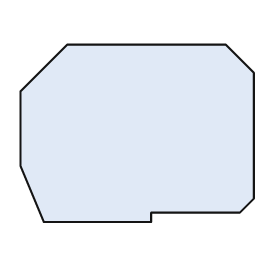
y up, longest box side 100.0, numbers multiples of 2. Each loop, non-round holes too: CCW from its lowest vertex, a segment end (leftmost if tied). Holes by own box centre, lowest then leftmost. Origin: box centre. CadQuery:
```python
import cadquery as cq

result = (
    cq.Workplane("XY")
    .moveTo(-40.0, -38.0)
    .lineTo(6.0, -38.0)
    .lineTo(6.0, -34.0)
    .lineTo(44.0, -34.0)
    .lineTo(50.0, -28.0)
    .lineTo(50.0, 26.0)
    .lineTo(38.0, 38.0)
    .lineTo(-30.0, 38.0)
    .lineTo(-50.0, 18.0)
    .lineTo(-50.0, -14.0)
    .close()
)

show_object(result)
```